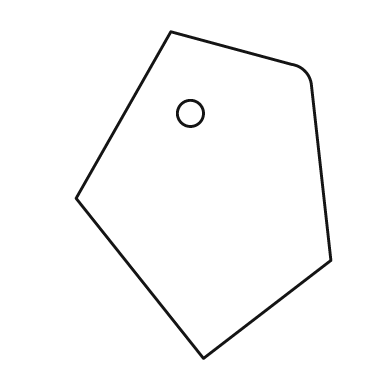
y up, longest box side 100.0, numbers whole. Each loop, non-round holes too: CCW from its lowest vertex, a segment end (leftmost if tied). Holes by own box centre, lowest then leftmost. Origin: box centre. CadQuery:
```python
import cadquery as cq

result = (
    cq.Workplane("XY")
    .moveTo(0.0, -50.0)
    .lineTo(39.0, -20.0)
    .lineTo(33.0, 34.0)
    .threePointArc((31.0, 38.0), (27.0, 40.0))
    .lineTo(-10.0, 50.0)
    .lineTo(-39.0, -1.0)
    .close()
    .moveTo(-4.0, 25.0)
    .circle(4.0)
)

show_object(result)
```